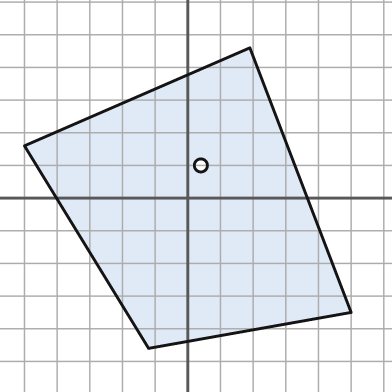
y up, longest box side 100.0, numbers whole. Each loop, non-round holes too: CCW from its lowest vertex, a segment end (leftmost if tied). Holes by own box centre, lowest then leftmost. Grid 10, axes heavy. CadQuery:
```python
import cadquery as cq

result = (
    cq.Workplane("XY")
    .moveTo(-12.0, -46.0)
    .lineTo(50.0, -35.0)
    .lineTo(19.0, 46.0)
    .lineTo(-50.0, 16.0)
    .close()
    .moveTo(4.0, 10.0)
    .circle(2.0)
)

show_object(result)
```